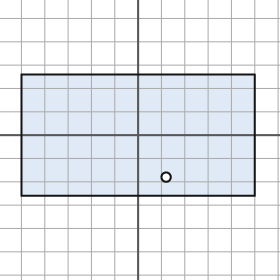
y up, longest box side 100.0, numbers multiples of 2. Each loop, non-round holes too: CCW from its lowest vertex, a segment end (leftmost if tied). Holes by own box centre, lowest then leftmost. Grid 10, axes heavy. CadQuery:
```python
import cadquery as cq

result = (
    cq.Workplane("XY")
    .moveTo(-50.0, -26.0)
    .lineTo(50.0, -26.0)
    .lineTo(50.0, 26.0)
    .lineTo(-50.0, 26.0)
    .close()
    .moveTo(12.0, -18.0)
    .circle(2.0)
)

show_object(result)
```